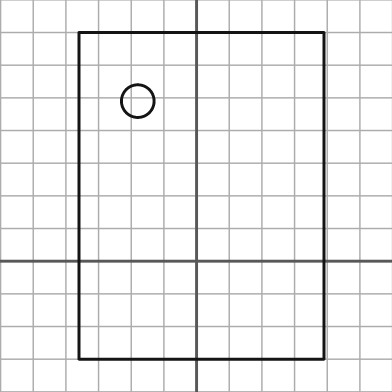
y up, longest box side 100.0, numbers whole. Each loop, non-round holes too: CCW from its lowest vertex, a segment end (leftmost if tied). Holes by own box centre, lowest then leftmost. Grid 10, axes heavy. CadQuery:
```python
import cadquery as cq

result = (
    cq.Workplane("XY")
    .moveTo(-36.0, -30.0)
    .lineTo(39.0, -30.0)
    .lineTo(39.0, 70.0)
    .lineTo(-36.0, 70.0)
    .close()
    .moveTo(-18.0, 49.0)
    .circle(5.0)
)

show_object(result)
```